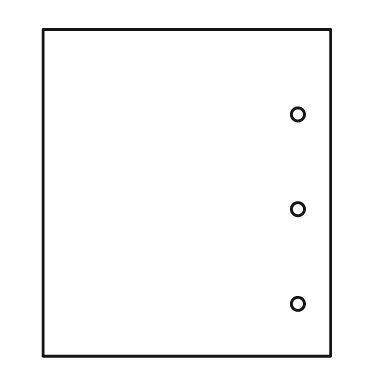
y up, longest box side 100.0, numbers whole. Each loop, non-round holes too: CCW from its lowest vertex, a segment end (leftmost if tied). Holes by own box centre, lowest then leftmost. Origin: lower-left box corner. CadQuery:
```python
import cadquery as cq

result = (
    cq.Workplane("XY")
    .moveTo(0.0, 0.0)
    .lineTo(88.0, 0.0)
    .lineTo(88.0, 100.0)
    .lineTo(0.0, 100.0)
    .close()
    .moveTo(78.0, 16.0)
    .circle(2.0)
    .moveTo(78.0, 45.0)
    .circle(2.0)
    .moveTo(78.0, 74.0)
    .circle(2.0)
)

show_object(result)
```